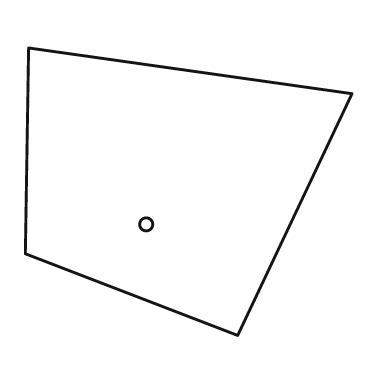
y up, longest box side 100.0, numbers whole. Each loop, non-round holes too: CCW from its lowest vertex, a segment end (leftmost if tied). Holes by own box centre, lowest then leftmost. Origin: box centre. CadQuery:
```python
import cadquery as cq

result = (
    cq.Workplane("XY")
    .moveTo(15.0, -44.0)
    .lineTo(50.0, 30.0)
    .lineTo(-49.0, 44.0)
    .lineTo(-50.0, -19.0)
    .close()
    .moveTo(-13.0, -10.0)
    .circle(2.0)
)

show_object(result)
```